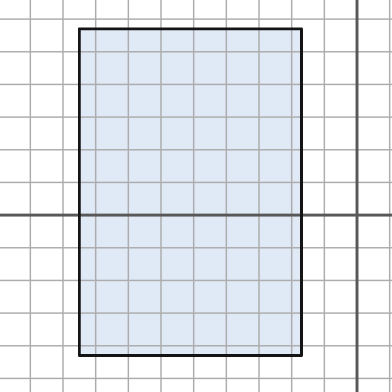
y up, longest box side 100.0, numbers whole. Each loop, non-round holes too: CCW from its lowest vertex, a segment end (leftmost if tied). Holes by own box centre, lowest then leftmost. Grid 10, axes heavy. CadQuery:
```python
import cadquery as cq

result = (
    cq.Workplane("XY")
    .moveTo(-85.0, -43.0)
    .lineTo(-17.0, -43.0)
    .lineTo(-17.0, 57.0)
    .lineTo(-85.0, 57.0)
    .close()
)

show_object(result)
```